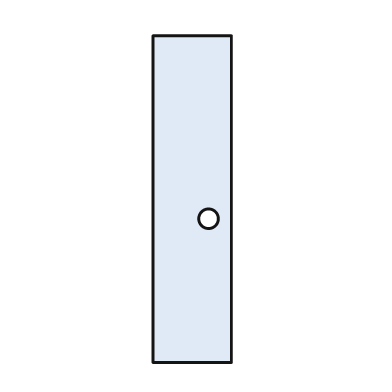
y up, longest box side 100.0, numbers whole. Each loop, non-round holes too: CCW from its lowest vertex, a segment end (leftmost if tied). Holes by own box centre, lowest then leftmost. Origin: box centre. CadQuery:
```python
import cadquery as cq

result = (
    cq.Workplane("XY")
    .moveTo(-12.0, -50.0)
    .lineTo(12.0, -50.0)
    .lineTo(12.0, 50.0)
    .lineTo(-12.0, 50.0)
    .close()
    .moveTo(5.0, -6.0)
    .circle(3.0)
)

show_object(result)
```